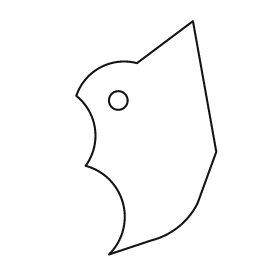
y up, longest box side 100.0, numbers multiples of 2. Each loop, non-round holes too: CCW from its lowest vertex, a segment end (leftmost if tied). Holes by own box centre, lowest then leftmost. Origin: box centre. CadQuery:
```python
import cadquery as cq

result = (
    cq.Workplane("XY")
    .moveTo(-16.0, -50.0)
    .lineTo(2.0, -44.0)
    .threePointArc((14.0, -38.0), (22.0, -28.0))
    .lineTo(30.0, -6.0)
    .lineTo(20.0, 50.0)
    .lineTo(-4.0, 32.0)
    .threePointArc((-20.0, 30.0), (-30.0, 18.0))
    .threePointArc((-22.0, 4.0), (-26.0, -12.0))
    .threePointArc((-10.0, -28.0), (-16.0, -50.0))
    .close()
    .moveTo(-12.0, 16.0)
    .circle(4.0)
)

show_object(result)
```